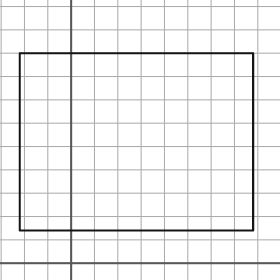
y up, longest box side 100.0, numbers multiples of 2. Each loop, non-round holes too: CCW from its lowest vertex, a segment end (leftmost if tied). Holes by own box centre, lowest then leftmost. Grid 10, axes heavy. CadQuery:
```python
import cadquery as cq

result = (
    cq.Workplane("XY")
    .moveTo(-22.0, 14.0)
    .lineTo(78.0, 14.0)
    .lineTo(78.0, 90.0)
    .lineTo(-22.0, 90.0)
    .close()
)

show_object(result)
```